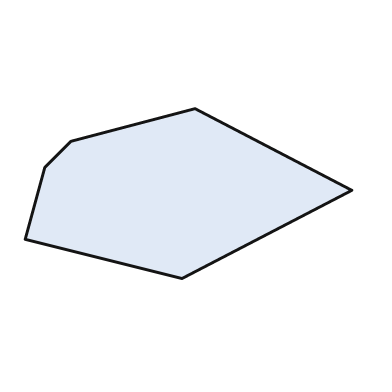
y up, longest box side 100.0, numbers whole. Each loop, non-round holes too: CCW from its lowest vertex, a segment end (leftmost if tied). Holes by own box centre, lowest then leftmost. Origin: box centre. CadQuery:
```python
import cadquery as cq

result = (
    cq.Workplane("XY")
    .moveTo(-2.0, -26.0)
    .lineTo(50.0, 1.0)
    .lineTo(2.0, 26.0)
    .lineTo(-36.0, 16.0)
    .lineTo(-44.0, 8.0)
    .lineTo(-50.0, -14.0)
    .close()
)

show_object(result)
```